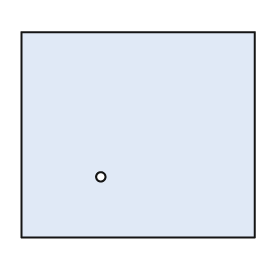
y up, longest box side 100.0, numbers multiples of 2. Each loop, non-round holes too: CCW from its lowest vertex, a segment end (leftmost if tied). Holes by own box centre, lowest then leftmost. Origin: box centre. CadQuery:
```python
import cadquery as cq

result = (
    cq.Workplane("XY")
    .moveTo(-50.0, -44.0)
    .lineTo(50.0, -44.0)
    .lineTo(50.0, 44.0)
    .lineTo(-50.0, 44.0)
    .close()
    .moveTo(-16.0, -18.0)
    .circle(2.0)
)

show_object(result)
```